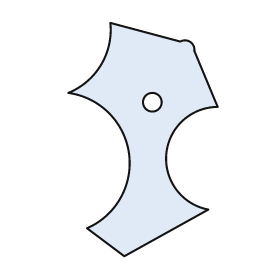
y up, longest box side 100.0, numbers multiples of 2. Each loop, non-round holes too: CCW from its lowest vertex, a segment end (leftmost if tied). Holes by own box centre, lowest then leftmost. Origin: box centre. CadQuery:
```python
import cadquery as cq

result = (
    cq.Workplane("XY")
    .moveTo(-8.0, -50.0)
    .lineTo(28.0, -30.0)
    .threePointArc((10.0, -6.0), (32.0, 14.0))
    .lineTo(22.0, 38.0)
    .threePointArc((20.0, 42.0), (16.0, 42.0))
    .lineTo(-14.0, 50.0)
    .threePointArc((-18.0, 32.0), (-32.0, 20.0))
    .threePointArc((-6.0, -6.0), (-24.0, -38.0))
    .close()
    .moveTo(4.0, 16.0)
    .circle(4.0)
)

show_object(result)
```